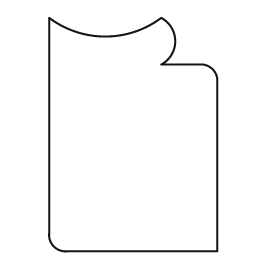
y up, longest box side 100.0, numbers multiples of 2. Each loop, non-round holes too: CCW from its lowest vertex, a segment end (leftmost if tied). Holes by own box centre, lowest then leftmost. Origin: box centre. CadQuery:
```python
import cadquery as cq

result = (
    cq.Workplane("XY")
    .moveTo(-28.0, -50.0)
    .lineTo(36.0, -50.0)
    .lineTo(36.0, 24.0)
    .threePointArc((34.0, 28.0), (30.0, 30.0))
    .lineTo(12.0, 30.0)
    .threePointArc((18.0, 40.0), (12.0, 50.0))
    .threePointArc((-12.0, 42.0), (-36.0, 50.0))
    .lineTo(-36.0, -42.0)
    .threePointArc((-34.0, -48.0), (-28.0, -50.0))
    .close()
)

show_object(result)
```